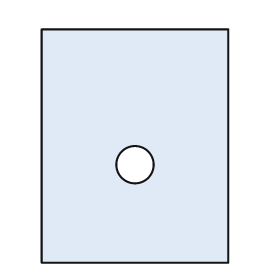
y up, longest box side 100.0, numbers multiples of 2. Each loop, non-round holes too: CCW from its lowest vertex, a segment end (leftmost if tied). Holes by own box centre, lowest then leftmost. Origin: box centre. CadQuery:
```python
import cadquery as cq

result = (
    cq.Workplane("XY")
    .moveTo(-40.0, -50.0)
    .lineTo(40.0, -50.0)
    .lineTo(40.0, 50.0)
    .lineTo(-40.0, 50.0)
    .close()
    .moveTo(0.0, -8.0)
    .circle(8.0)
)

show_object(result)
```